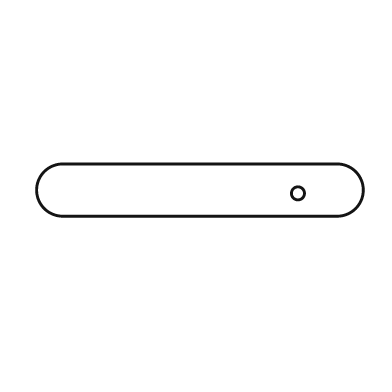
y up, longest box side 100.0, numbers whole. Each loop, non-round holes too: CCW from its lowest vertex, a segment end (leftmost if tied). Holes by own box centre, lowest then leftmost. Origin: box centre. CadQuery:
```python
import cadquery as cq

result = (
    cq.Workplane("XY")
    .moveTo(-42.0, -8.0)
    .lineTo(42.0, -8.0)
    .threePointArc((50.0, 0.0), (42.0, 8.0))
    .lineTo(-42.0, 8.0)
    .threePointArc((-50.0, 0.0), (-42.0, -8.0))
    .close()
    .moveTo(30.0, -1.0)
    .circle(2.0)
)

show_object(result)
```